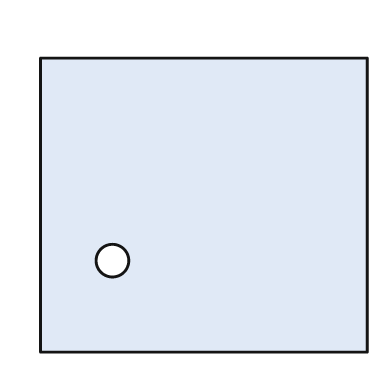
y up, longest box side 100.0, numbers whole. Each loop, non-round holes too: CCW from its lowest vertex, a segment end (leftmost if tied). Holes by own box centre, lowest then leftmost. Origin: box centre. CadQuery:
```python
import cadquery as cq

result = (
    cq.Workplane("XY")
    .moveTo(-50.0, -45.0)
    .lineTo(50.0, -45.0)
    .lineTo(50.0, 45.0)
    .lineTo(-50.0, 45.0)
    .close()
    .moveTo(-28.0, -17.0)
    .circle(5.0)
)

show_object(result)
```